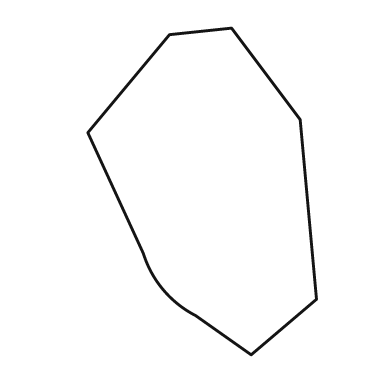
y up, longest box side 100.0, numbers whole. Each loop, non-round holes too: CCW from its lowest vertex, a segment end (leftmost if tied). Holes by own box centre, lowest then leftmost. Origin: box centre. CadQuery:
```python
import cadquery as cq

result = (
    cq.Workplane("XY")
    .moveTo(15.0, -50.0)
    .lineTo(35.0, -33.0)
    .lineTo(30.0, 22.0)
    .lineTo(9.0, 50.0)
    .lineTo(-10.0, 48.0)
    .lineTo(-35.0, 18.0)
    .lineTo(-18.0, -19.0)
    .threePointArc((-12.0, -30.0), (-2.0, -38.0))
    .close()
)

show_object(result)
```